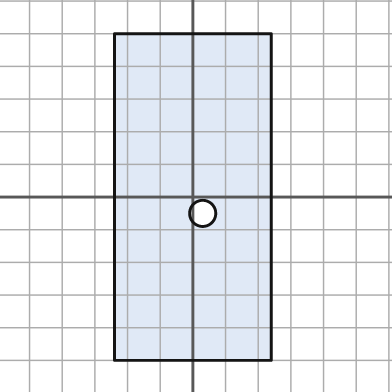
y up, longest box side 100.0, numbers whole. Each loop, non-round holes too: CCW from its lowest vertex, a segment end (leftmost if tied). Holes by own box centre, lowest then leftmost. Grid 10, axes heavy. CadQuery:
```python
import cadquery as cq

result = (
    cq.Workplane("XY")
    .moveTo(-24.0, -50.0)
    .lineTo(24.0, -50.0)
    .lineTo(24.0, 50.0)
    .lineTo(-24.0, 50.0)
    .close()
    .moveTo(3.0, -5.0)
    .circle(4.0)
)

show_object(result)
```